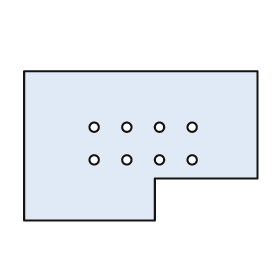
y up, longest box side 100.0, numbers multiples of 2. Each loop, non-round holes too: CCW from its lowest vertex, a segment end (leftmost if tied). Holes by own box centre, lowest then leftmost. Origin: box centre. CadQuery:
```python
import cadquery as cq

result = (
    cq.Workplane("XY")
    .moveTo(-50.0, -32.0)
    .lineTo(6.0, -32.0)
    .lineTo(6.0, -14.0)
    .lineTo(50.0, -14.0)
    .lineTo(50.0, 32.0)
    .lineTo(-50.0, 32.0)
    .close()
    .moveTo(-20.0, -6.0)
    .circle(2.0)
    .moveTo(-6.0, -6.0)
    .circle(2.0)
    .moveTo(8.0, -6.0)
    .circle(2.0)
    .moveTo(22.0, -6.0)
    .circle(2.0)
    .moveTo(-20.0, 8.0)
    .circle(2.0)
    .moveTo(-6.0, 8.0)
    .circle(2.0)
    .moveTo(8.0, 8.0)
    .circle(2.0)
    .moveTo(22.0, 8.0)
    .circle(2.0)
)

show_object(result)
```